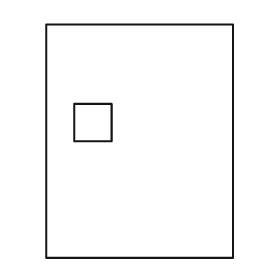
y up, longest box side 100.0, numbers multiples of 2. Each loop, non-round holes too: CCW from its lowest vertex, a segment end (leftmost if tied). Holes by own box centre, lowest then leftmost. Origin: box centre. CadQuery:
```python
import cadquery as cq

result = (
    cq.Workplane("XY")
    .moveTo(-40.0, -50.0)
    .lineTo(40.0, -50.0)
    .lineTo(40.0, 50.0)
    .lineTo(-40.0, 50.0)
    .close()
    .moveTo(-28.0, 0.0)
    .lineTo(-12.0, 0.0)
    .lineTo(-12.0, 16.0)
    .lineTo(-28.0, 16.0)
    .close()
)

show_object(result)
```